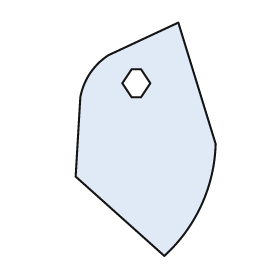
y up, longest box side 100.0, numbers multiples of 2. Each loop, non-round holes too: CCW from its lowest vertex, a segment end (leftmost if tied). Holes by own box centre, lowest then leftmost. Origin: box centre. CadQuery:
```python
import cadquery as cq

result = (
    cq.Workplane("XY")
    .moveTo(8.0, -50.0)
    .threePointArc((24.0, -28.0), (30.0, -2.0))
    .lineTo(14.0, 50.0)
    .lineTo(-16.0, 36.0)
    .threePointArc((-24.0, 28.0), (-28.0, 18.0))
    .lineTo(-30.0, -16.0)
    .close()
    .moveTo(-6.0, 18.0)
    .lineTo(-2.0, 18.0)
    .lineTo(2.0, 24.0)
    .lineTo(-2.0, 30.0)
    .lineTo(-6.0, 30.0)
    .lineTo(-10.0, 24.0)
    .close()
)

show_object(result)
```